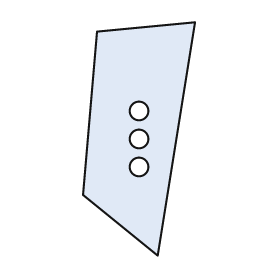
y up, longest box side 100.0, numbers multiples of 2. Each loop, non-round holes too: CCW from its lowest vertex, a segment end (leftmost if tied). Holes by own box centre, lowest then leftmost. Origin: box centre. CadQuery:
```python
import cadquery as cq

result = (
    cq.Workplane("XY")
    .moveTo(8.0, -50.0)
    .lineTo(24.0, 50.0)
    .lineTo(-18.0, 46.0)
    .lineTo(-24.0, -24.0)
    .close()
    .moveTo(0.0, -12.0)
    .circle(4.0)
    .moveTo(0.0, 0.0)
    .circle(4.0)
    .moveTo(0.0, 12.0)
    .circle(4.0)
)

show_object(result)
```